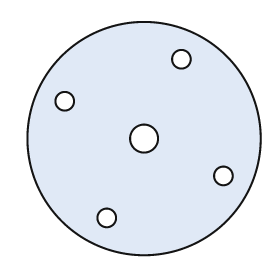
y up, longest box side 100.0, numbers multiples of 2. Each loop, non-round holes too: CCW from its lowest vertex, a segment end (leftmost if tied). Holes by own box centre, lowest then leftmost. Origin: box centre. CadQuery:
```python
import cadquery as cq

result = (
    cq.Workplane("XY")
    .moveTo(0.0, 0.0)
    .circle(50.0)
    .moveTo(-16.0, -34.0)
    .circle(4.0)
    .moveTo(34.0, -16.0)
    .circle(4.0)
    .moveTo(0.0, 0.0)
    .circle(6.0)
    .moveTo(-34.0, 16.0)
    .circle(4.0)
    .moveTo(16.0, 34.0)
    .circle(4.0)
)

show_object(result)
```